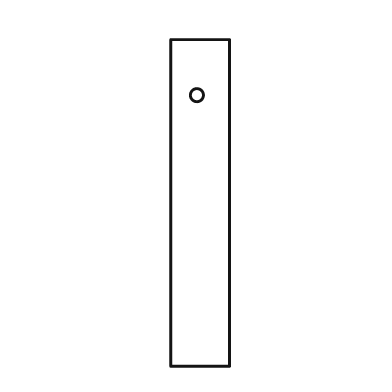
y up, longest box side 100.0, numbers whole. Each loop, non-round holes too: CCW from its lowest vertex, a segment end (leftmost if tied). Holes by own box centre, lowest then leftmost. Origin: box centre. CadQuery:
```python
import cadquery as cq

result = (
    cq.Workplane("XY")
    .moveTo(-9.0, -50.0)
    .lineTo(9.0, -50.0)
    .lineTo(9.0, 50.0)
    .lineTo(-9.0, 50.0)
    .close()
    .moveTo(-1.0, 33.0)
    .circle(2.0)
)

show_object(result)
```